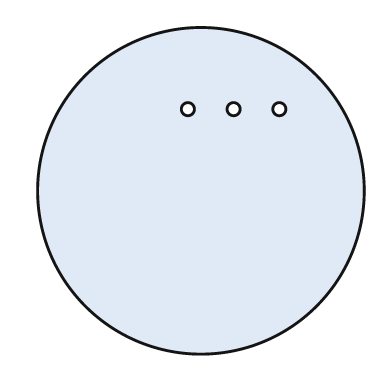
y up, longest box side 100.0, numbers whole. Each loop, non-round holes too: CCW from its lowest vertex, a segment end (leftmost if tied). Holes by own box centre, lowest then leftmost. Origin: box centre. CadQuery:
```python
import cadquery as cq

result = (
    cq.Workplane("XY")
    .moveTo(0.0, 0.0)
    .circle(50.0)
    .moveTo(-4.0, 25.0)
    .circle(2.0)
    .moveTo(10.0, 25.0)
    .circle(2.0)
    .moveTo(24.0, 25.0)
    .circle(2.0)
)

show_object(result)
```